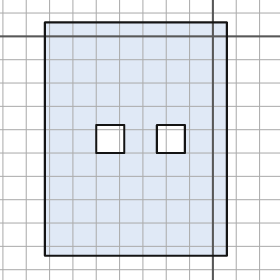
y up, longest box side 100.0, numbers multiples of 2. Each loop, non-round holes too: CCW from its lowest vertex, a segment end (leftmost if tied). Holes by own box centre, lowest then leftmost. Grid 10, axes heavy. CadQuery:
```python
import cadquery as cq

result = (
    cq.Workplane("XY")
    .moveTo(-72.0, -94.0)
    .lineTo(6.0, -94.0)
    .lineTo(6.0, 6.0)
    .lineTo(-72.0, 6.0)
    .close()
    .moveTo(-50.0, -50.0)
    .lineTo(-38.0, -50.0)
    .lineTo(-38.0, -38.0)
    .lineTo(-50.0, -38.0)
    .close()
    .moveTo(-24.0, -50.0)
    .lineTo(-12.0, -50.0)
    .lineTo(-12.0, -38.0)
    .lineTo(-24.0, -38.0)
    .close()
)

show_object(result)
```